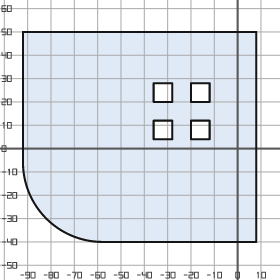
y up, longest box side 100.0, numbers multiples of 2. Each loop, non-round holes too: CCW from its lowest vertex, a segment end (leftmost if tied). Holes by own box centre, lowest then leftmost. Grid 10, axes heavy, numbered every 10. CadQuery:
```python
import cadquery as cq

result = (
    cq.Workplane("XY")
    .moveTo(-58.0, -40.0)
    .lineTo(8.0, -40.0)
    .lineTo(8.0, 50.0)
    .lineTo(-92.0, 50.0)
    .lineTo(-92.0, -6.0)
    .threePointArc((-82.0, -30.0), (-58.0, -40.0))
    .close()
    .moveTo(-36.0, 4.0)
    .lineTo(-28.0, 4.0)
    .lineTo(-28.0, 12.0)
    .lineTo(-36.0, 12.0)
    .close()
    .moveTo(-20.0, 4.0)
    .lineTo(-12.0, 4.0)
    .lineTo(-12.0, 12.0)
    .lineTo(-20.0, 12.0)
    .close()
    .moveTo(-36.0, 20.0)
    .lineTo(-28.0, 20.0)
    .lineTo(-28.0, 28.0)
    .lineTo(-36.0, 28.0)
    .close()
    .moveTo(-20.0, 20.0)
    .lineTo(-12.0, 20.0)
    .lineTo(-12.0, 28.0)
    .lineTo(-20.0, 28.0)
    .close()
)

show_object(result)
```